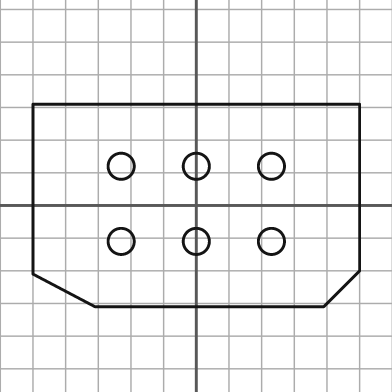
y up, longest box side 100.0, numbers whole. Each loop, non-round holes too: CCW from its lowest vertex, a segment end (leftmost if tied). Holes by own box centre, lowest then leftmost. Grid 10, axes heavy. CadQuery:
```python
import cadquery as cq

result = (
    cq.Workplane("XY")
    .moveTo(-31.0, -31.0)
    .lineTo(39.0, -31.0)
    .lineTo(50.0, -20.0)
    .lineTo(50.0, 31.0)
    .lineTo(-50.0, 31.0)
    .lineTo(-50.0, -21.0)
    .close()
    .moveTo(-23.0, -11.0)
    .circle(4.0)
    .moveTo(0.0, -11.0)
    .circle(4.0)
    .moveTo(23.0, -11.0)
    .circle(4.0)
    .moveTo(-23.0, 12.0)
    .circle(4.0)
    .moveTo(0.0, 12.0)
    .circle(4.0)
    .moveTo(23.0, 12.0)
    .circle(4.0)
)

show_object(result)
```